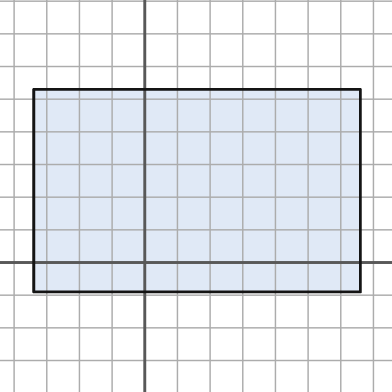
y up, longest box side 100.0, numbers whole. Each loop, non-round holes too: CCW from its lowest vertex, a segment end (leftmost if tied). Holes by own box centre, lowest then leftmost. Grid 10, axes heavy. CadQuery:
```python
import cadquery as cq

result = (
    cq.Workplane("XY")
    .moveTo(-34.0, -9.0)
    .lineTo(66.0, -9.0)
    .lineTo(66.0, 53.0)
    .lineTo(-34.0, 53.0)
    .close()
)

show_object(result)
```